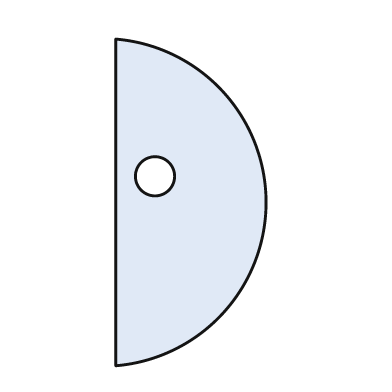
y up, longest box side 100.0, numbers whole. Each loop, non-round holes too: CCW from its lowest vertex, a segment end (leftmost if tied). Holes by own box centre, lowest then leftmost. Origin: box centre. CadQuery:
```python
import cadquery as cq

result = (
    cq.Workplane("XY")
    .moveTo(-23.0, -50.0)
    .threePointArc((23.0, 0.0), (-23.0, 50.0))
    .close()
    .moveTo(-11.0, 8.0)
    .circle(6.0)
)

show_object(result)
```